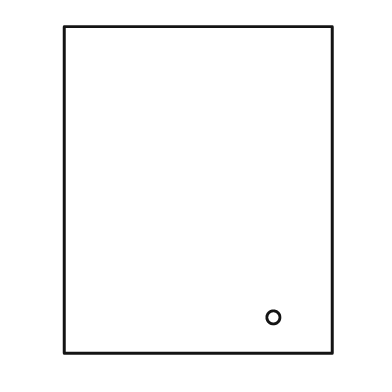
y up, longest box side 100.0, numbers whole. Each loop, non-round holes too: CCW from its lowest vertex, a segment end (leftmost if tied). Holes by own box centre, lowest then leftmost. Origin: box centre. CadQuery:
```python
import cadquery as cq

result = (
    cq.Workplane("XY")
    .moveTo(-41.0, -50.0)
    .lineTo(41.0, -50.0)
    .lineTo(41.0, 50.0)
    .lineTo(-41.0, 50.0)
    .close()
    .moveTo(23.0, -39.0)
    .circle(2.0)
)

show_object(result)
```